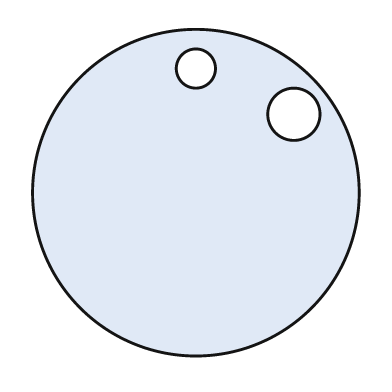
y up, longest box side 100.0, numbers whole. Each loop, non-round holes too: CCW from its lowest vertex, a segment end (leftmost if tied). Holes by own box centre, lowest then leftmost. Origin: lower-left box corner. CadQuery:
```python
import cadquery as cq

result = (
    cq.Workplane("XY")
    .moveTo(50.0, 50.0)
    .circle(50.0)
    .moveTo(80.0, 74.0)
    .circle(8.0)
    .moveTo(50.0, 88.0)
    .circle(6.0)
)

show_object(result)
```